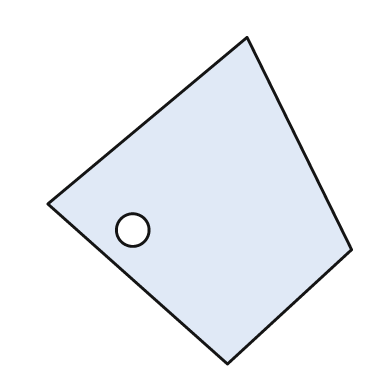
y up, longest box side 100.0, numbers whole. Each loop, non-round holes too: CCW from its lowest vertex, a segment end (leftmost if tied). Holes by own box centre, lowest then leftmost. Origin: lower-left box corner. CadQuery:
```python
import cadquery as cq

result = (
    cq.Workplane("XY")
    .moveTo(55.0, 0.0)
    .lineTo(93.0, 35.0)
    .lineTo(61.0, 100.0)
    .lineTo(0.0, 49.0)
    .close()
    .moveTo(26.0, 41.0)
    .circle(5.0)
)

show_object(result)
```